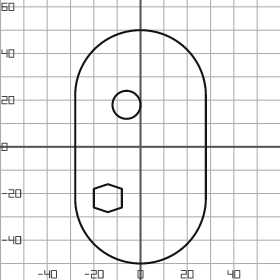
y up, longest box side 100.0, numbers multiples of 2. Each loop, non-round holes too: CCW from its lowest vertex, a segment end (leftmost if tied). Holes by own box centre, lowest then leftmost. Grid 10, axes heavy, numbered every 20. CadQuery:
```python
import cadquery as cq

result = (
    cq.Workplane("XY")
    .moveTo(-28.0, -22.0)
    .threePointArc((0.0, -50.0), (28.0, -22.0))
    .lineTo(28.0, 22.0)
    .threePointArc((0.0, 50.0), (-28.0, 22.0))
    .close()
    .moveTo(-14.0, -28.0)
    .lineTo(-8.0, -26.0)
    .lineTo(-8.0, -18.0)
    .lineTo(-14.0, -16.0)
    .lineTo(-20.0, -18.0)
    .lineTo(-20.0, -26.0)
    .close()
    .moveTo(-6.0, 18.0)
    .circle(6.0)
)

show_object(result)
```